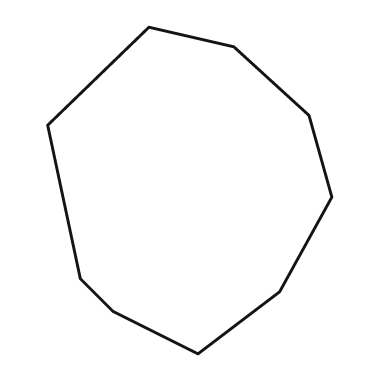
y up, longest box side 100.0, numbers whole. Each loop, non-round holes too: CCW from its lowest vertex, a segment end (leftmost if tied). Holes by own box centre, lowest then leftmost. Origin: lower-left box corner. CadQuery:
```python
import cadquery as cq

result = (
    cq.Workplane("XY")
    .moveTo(46.0, 0.0)
    .lineTo(71.0, 19.0)
    .lineTo(87.0, 48.0)
    .lineTo(80.0, 73.0)
    .lineTo(57.0, 94.0)
    .lineTo(31.0, 100.0)
    .lineTo(0.0, 70.0)
    .lineTo(10.0, 23.0)
    .lineTo(20.0, 13.0)
    .close()
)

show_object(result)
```